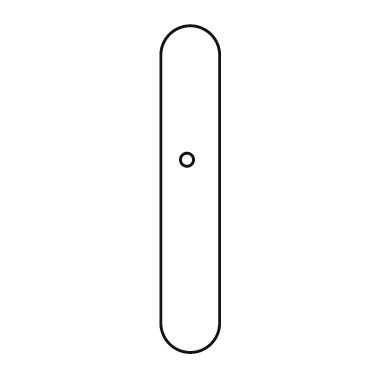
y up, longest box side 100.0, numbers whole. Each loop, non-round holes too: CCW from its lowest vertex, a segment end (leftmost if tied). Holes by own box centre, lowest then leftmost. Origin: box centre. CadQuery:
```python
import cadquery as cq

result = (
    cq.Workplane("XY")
    .moveTo(-9.0, -41.0)
    .threePointArc((0.0, -50.0), (9.0, -41.0))
    .lineTo(9.0, 41.0)
    .threePointArc((0.0, 50.0), (-9.0, 41.0))
    .close()
    .moveTo(-1.0, 9.0)
    .circle(2.0)
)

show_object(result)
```